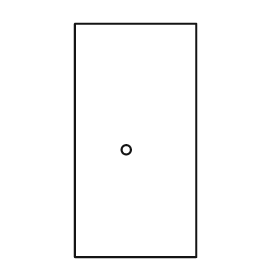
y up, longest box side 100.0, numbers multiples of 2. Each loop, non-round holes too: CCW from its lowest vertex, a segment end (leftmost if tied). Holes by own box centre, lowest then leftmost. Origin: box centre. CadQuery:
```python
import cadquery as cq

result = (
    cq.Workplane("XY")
    .moveTo(-26.0, -50.0)
    .lineTo(26.0, -50.0)
    .lineTo(26.0, 50.0)
    .lineTo(-26.0, 50.0)
    .close()
    .moveTo(-4.0, -4.0)
    .circle(2.0)
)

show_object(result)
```